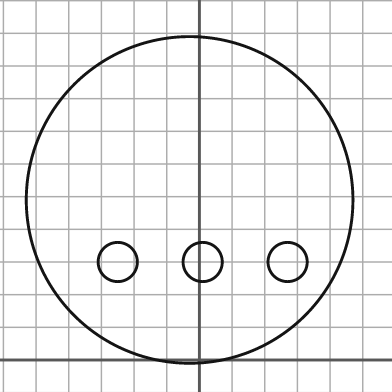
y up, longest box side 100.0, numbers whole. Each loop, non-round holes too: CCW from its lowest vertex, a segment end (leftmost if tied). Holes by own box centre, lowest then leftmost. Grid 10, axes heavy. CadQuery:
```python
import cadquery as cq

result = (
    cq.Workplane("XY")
    .moveTo(-3.0, 49.0)
    .circle(50.0)
    .moveTo(-25.0, 30.0)
    .circle(6.0)
    .moveTo(1.0, 30.0)
    .circle(6.0)
    .moveTo(27.0, 30.0)
    .circle(6.0)
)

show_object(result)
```